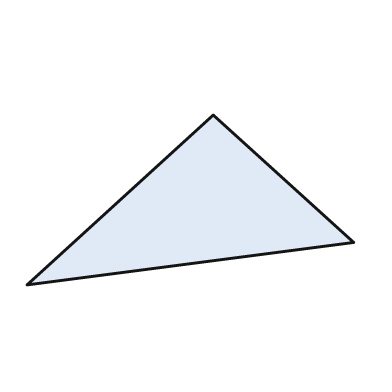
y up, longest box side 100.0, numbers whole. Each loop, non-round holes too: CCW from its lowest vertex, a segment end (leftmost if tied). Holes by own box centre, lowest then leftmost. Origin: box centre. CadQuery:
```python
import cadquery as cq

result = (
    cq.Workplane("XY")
    .moveTo(-50.0, -26.0)
    .lineTo(50.0, -13.0)
    .lineTo(7.0, 26.0)
    .close()
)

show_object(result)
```